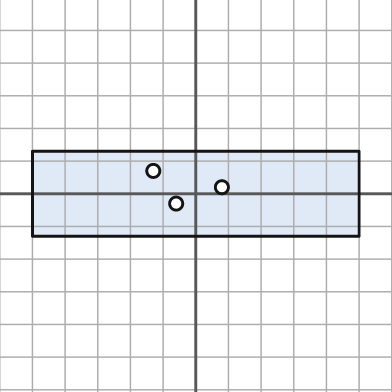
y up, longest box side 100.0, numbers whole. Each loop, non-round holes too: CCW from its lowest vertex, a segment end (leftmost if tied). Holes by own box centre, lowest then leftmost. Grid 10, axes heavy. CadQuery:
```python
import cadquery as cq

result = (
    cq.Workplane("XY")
    .moveTo(-50.0, -13.0)
    .lineTo(50.0, -13.0)
    .lineTo(50.0, 13.0)
    .lineTo(-50.0, 13.0)
    .close()
    .moveTo(-6.0, -3.0)
    .circle(2.0)
    .moveTo(8.0, 2.0)
    .circle(2.0)
    .moveTo(-13.0, 7.0)
    .circle(2.0)
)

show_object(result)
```